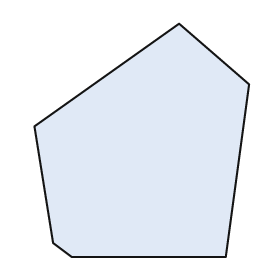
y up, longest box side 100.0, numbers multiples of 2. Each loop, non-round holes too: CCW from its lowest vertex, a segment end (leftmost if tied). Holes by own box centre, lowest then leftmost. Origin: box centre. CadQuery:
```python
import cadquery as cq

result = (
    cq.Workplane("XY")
    .moveTo(-30.0, -50.0)
    .lineTo(36.0, -50.0)
    .lineTo(46.0, 24.0)
    .lineTo(16.0, 50.0)
    .lineTo(-46.0, 6.0)
    .lineTo(-38.0, -44.0)
    .close()
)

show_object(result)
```